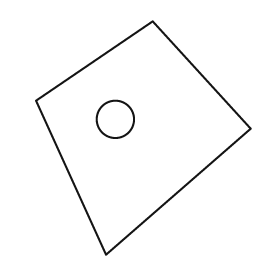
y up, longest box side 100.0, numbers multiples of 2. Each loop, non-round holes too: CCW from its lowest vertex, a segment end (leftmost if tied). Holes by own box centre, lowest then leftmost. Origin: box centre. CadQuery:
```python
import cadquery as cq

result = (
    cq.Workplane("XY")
    .moveTo(-16.0, -50.0)
    .lineTo(46.0, 4.0)
    .lineTo(4.0, 50.0)
    .lineTo(-46.0, 16.0)
    .close()
    .moveTo(-12.0, 8.0)
    .circle(8.0)
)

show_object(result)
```